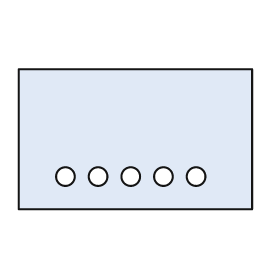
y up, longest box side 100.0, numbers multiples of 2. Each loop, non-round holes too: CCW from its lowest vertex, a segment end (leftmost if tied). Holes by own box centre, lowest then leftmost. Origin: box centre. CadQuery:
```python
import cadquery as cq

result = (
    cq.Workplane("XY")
    .moveTo(-50.0, -30.0)
    .lineTo(50.0, -30.0)
    .lineTo(50.0, 30.0)
    .lineTo(-50.0, 30.0)
    .close()
    .moveTo(-30.0, -16.0)
    .circle(4.0)
    .moveTo(-16.0, -16.0)
    .circle(4.0)
    .moveTo(-2.0, -16.0)
    .circle(4.0)
    .moveTo(12.0, -16.0)
    .circle(4.0)
    .moveTo(26.0, -16.0)
    .circle(4.0)
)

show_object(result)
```